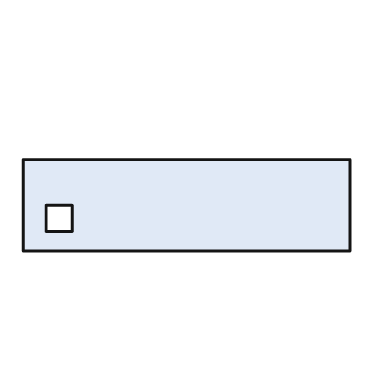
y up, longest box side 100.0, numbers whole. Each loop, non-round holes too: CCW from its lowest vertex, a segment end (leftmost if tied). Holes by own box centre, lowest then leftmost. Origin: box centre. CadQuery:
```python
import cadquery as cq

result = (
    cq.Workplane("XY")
    .moveTo(-50.0, -14.0)
    .lineTo(50.0, -14.0)
    .lineTo(50.0, 14.0)
    .lineTo(-50.0, 14.0)
    .close()
    .moveTo(-43.0, -8.0)
    .lineTo(-35.0, -8.0)
    .lineTo(-35.0, 0.0)
    .lineTo(-43.0, 0.0)
    .close()
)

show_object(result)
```